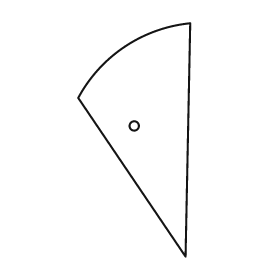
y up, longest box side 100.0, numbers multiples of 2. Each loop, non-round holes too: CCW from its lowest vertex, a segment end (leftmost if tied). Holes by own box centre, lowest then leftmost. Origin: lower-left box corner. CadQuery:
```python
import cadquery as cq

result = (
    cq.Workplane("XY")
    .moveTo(46.0, 0.0)
    .lineTo(48.0, 100.0)
    .threePointArc((20.0, 90.0), (0.0, 68.0))
    .close()
    .moveTo(24.0, 56.0)
    .circle(2.0)
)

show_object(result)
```